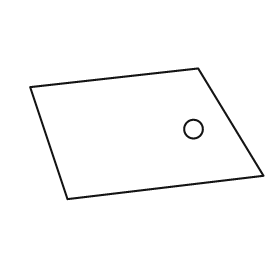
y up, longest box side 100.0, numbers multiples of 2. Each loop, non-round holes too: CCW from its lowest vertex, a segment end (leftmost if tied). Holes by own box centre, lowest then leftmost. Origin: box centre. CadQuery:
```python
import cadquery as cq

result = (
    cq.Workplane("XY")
    .moveTo(-34.0, -28.0)
    .lineTo(50.0, -18.0)
    .lineTo(22.0, 28.0)
    .lineTo(-50.0, 20.0)
    .close()
    .moveTo(20.0, 2.0)
    .circle(4.0)
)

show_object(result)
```